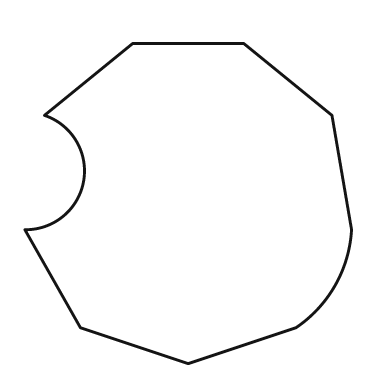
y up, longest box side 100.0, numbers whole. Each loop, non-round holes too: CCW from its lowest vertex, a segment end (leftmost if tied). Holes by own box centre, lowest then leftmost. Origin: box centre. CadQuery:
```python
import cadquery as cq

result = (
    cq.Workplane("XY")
    .moveTo(0.0, -49.0)
    .lineTo(33.0, -38.0)
    .threePointArc((45.0, -25.0), (50.0, -8.0))
    .lineTo(44.0, 27.0)
    .lineTo(17.0, 49.0)
    .lineTo(-17.0, 49.0)
    .lineTo(-44.0, 27.0)
    .threePointArc((-32.0, 7.0), (-50.0, -8.0))
    .lineTo(-33.0, -38.0)
    .close()
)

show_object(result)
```